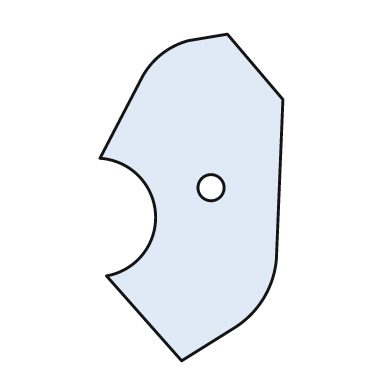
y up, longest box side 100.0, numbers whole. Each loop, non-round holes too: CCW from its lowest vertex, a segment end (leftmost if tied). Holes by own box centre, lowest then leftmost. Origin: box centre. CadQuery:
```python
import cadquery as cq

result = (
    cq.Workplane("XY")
    .moveTo(-3.0, -50.0)
    .lineTo(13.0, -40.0)
    .threePointArc((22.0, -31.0), (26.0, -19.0))
    .lineTo(28.0, 30.0)
    .lineTo(11.0, 50.0)
    .lineTo(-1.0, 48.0)
    .threePointArc((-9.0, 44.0), (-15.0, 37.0))
    .lineTo(-28.0, 12.0)
    .threePointArc((-11.0, -5.0), (-26.0, -24.0))
    .close()
    .moveTo(6.0, 3.0)
    .circle(4.0)
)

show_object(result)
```